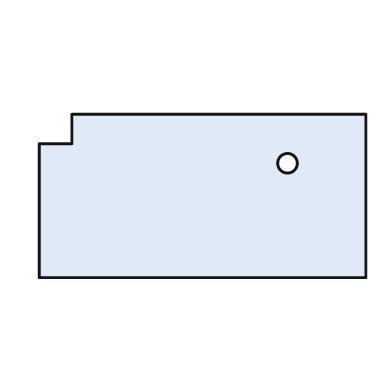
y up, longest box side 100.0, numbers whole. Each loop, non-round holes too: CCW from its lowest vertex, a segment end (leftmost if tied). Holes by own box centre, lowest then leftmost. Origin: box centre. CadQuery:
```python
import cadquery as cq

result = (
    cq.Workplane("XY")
    .moveTo(-50.0, -25.0)
    .lineTo(50.0, -25.0)
    .lineTo(50.0, 25.0)
    .lineTo(-40.0, 25.0)
    .lineTo(-40.0, 16.0)
    .lineTo(-50.0, 16.0)
    .close()
    .moveTo(26.0, 10.0)
    .circle(3.0)
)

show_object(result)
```